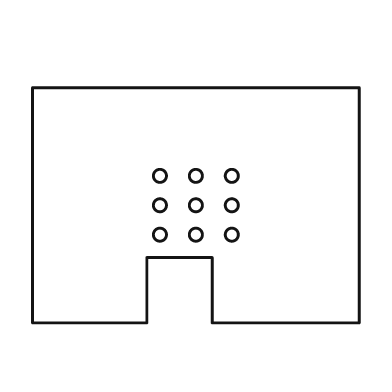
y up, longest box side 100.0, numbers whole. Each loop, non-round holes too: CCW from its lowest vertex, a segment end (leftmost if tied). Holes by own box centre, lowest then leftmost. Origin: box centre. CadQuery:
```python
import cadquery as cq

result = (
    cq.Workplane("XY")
    .moveTo(-50.0, -36.0)
    .lineTo(-15.0, -36.0)
    .lineTo(-15.0, -16.0)
    .lineTo(5.0, -16.0)
    .lineTo(5.0, -36.0)
    .lineTo(50.0, -36.0)
    .lineTo(50.0, 36.0)
    .lineTo(-50.0, 36.0)
    .close()
    .moveTo(-11.0, -9.0)
    .circle(2.0)
    .moveTo(0.0, -9.0)
    .circle(2.0)
    .moveTo(11.0, -9.0)
    .circle(2.0)
    .moveTo(-11.0, 0.0)
    .circle(2.0)
    .moveTo(0.0, 0.0)
    .circle(2.0)
    .moveTo(11.0, 0.0)
    .circle(2.0)
    .moveTo(-11.0, 9.0)
    .circle(2.0)
    .moveTo(0.0, 9.0)
    .circle(2.0)
    .moveTo(11.0, 9.0)
    .circle(2.0)
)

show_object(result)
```